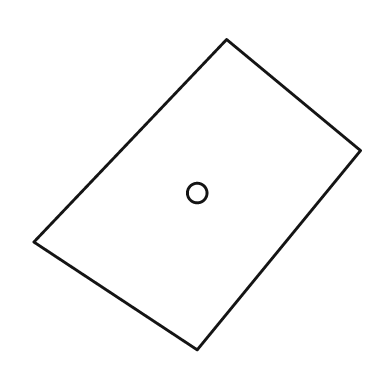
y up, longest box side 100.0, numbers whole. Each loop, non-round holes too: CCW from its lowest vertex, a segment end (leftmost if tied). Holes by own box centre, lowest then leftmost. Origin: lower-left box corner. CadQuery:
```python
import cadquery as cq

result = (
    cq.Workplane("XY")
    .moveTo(50.0, 0.0)
    .lineTo(100.0, 61.0)
    .lineTo(59.0, 95.0)
    .lineTo(0.0, 33.0)
    .close()
    .moveTo(50.0, 48.0)
    .circle(3.0)
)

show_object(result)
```